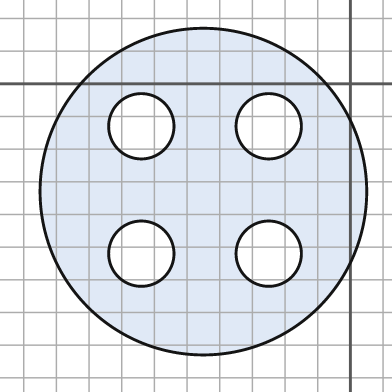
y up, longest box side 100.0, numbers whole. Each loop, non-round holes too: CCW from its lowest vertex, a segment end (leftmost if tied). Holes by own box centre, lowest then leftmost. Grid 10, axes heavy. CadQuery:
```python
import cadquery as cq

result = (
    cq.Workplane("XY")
    .moveTo(-45.0, -33.0)
    .circle(50.0)
    .moveTo(-64.0, -52.0)
    .circle(10.0)
    .moveTo(-25.0, -52.0)
    .circle(10.0)
    .moveTo(-64.0, -13.0)
    .circle(10.0)
    .moveTo(-25.0, -13.0)
    .circle(10.0)
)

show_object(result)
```